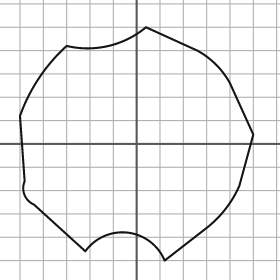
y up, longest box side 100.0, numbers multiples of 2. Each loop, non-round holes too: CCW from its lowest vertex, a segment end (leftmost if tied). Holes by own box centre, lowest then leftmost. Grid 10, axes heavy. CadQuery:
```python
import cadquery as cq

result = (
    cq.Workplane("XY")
    .moveTo(12.0, -50.0)
    .lineTo(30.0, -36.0)
    .threePointArc((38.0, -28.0), (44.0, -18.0))
    .lineTo(50.0, 4.0)
    .lineTo(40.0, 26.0)
    .threePointArc((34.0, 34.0), (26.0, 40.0))
    .lineTo(4.0, 50.0)
    .threePointArc((-12.0, 42.0), (-30.0, 42.0))
    .threePointArc((-42.0, 28.0), (-50.0, 12.0))
    .lineTo(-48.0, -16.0)
    .threePointArc((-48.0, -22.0), (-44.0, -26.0))
    .lineTo(-22.0, -46.0)
    .threePointArc((-4.0, -38.0), (12.0, -50.0))
    .close()
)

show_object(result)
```